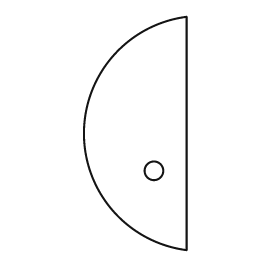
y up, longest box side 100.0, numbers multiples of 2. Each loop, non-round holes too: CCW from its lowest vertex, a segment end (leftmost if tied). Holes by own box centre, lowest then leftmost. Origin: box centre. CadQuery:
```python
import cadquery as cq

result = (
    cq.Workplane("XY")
    .moveTo(22.0, -50.0)
    .lineTo(22.0, 50.0)
    .threePointArc((-22.0, 0.0), (22.0, -50.0))
    .close()
    .moveTo(8.0, -16.0)
    .circle(4.0)
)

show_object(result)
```